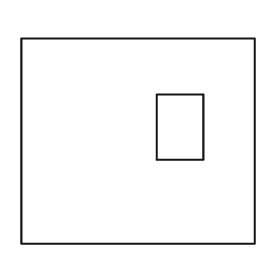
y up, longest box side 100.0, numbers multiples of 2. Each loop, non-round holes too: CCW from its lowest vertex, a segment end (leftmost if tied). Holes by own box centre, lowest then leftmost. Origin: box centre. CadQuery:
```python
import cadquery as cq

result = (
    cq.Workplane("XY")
    .moveTo(-50.0, -44.0)
    .lineTo(50.0, -44.0)
    .lineTo(50.0, 44.0)
    .lineTo(-50.0, 44.0)
    .close()
    .moveTo(8.0, -8.0)
    .lineTo(28.0, -8.0)
    .lineTo(28.0, 20.0)
    .lineTo(8.0, 20.0)
    .close()
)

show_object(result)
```